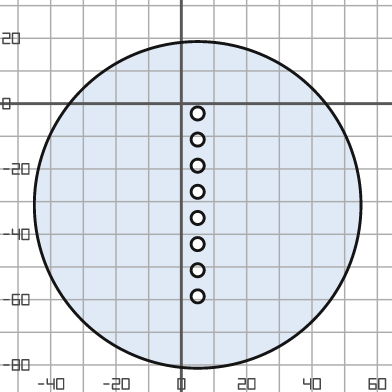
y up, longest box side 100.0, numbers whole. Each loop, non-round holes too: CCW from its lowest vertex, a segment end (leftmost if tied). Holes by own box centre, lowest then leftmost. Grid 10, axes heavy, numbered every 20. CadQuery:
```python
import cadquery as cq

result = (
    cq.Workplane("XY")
    .moveTo(5.0, -31.0)
    .circle(50.0)
    .moveTo(5.0, -59.0)
    .circle(2.0)
    .moveTo(5.0, -51.0)
    .circle(2.0)
    .moveTo(5.0, -43.0)
    .circle(2.0)
    .moveTo(5.0, -35.0)
    .circle(2.0)
    .moveTo(5.0, -27.0)
    .circle(2.0)
    .moveTo(5.0, -19.0)
    .circle(2.0)
    .moveTo(5.0, -11.0)
    .circle(2.0)
    .moveTo(5.0, -3.0)
    .circle(2.0)
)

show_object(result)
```